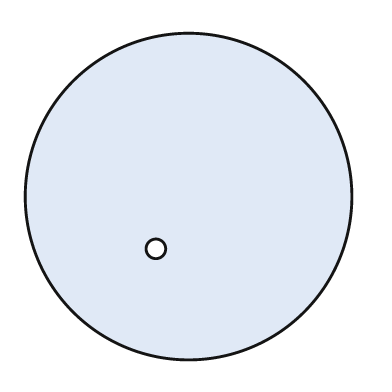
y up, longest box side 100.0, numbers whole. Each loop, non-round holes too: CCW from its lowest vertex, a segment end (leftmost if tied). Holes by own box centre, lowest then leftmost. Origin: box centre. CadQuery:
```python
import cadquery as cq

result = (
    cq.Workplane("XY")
    .moveTo(0.0, 0.0)
    .circle(50.0)
    .moveTo(-10.0, -16.0)
    .circle(3.0)
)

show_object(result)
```